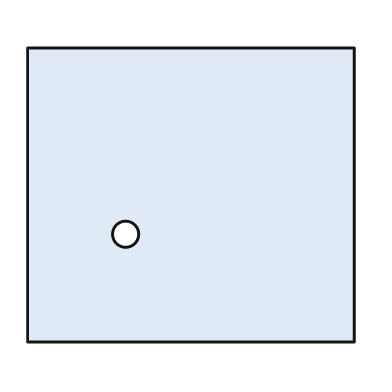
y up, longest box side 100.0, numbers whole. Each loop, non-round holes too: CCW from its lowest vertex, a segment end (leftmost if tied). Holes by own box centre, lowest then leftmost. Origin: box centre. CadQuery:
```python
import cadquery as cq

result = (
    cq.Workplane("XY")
    .moveTo(-50.0, -45.0)
    .lineTo(50.0, -45.0)
    .lineTo(50.0, 45.0)
    .lineTo(-50.0, 45.0)
    .close()
    .moveTo(-20.0, -12.0)
    .circle(4.0)
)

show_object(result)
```